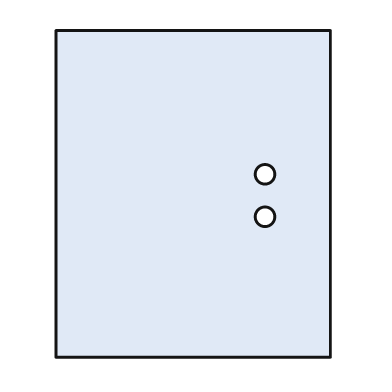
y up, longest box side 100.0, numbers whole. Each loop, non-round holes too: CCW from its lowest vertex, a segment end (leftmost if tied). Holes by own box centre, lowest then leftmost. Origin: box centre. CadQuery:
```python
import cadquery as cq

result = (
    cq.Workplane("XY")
    .moveTo(-42.0, -50.0)
    .lineTo(42.0, -50.0)
    .lineTo(42.0, 50.0)
    .lineTo(-42.0, 50.0)
    .close()
    .moveTo(22.0, -7.0)
    .circle(3.0)
    .moveTo(22.0, 6.0)
    .circle(3.0)
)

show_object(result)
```